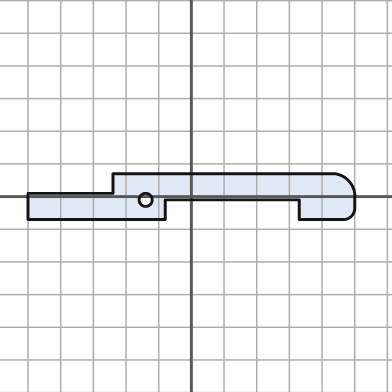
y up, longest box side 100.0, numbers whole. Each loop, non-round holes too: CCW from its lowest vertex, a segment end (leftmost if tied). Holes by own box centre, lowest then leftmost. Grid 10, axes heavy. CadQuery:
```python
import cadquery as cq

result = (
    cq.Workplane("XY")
    .moveTo(-50.0, -7.0)
    .lineTo(-8.0, -7.0)
    .lineTo(-8.0, -1.0)
    .lineTo(33.0, -1.0)
    .lineTo(33.0, -7.0)
    .lineTo(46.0, -7.0)
    .threePointArc((49.0, -6.0), (50.0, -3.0))
    .lineTo(50.0, 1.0)
    .threePointArc((48.0, 5.0), (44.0, 7.0))
    .lineTo(-24.0, 7.0)
    .lineTo(-24.0, 1.0)
    .lineTo(-50.0, 1.0)
    .close()
    .moveTo(-14.0, -1.0)
    .circle(2.0)
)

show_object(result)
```